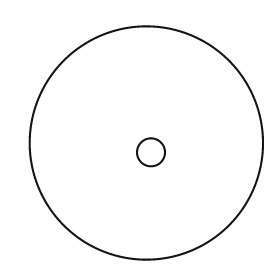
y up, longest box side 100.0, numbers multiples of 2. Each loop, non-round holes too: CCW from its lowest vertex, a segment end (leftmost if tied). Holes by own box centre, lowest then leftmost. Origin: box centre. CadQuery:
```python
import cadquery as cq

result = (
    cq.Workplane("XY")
    .moveTo(0.0, 0.0)
    .circle(50.0)
    .moveTo(2.0, -4.0)
    .circle(6.0)
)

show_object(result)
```